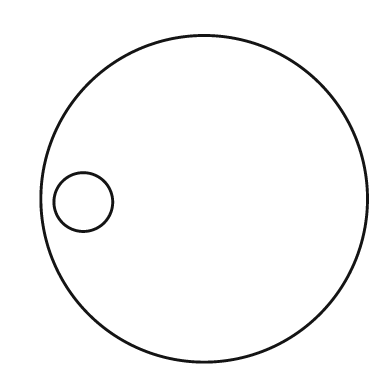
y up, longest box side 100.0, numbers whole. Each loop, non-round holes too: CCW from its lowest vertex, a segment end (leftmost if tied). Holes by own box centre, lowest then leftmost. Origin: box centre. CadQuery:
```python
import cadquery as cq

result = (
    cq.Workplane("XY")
    .moveTo(0.0, 0.0)
    .circle(50.0)
    .moveTo(-37.0, -1.0)
    .circle(9.0)
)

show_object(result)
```